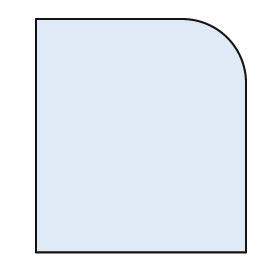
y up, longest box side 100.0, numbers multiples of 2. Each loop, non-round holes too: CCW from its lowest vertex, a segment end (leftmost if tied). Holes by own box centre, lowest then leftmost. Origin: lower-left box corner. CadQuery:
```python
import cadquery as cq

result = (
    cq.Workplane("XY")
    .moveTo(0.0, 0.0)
    .lineTo(90.0, 0.0)
    .lineTo(90.0, 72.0)
    .threePointArc((82.0, 92.0), (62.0, 100.0))
    .lineTo(0.0, 100.0)
    .close()
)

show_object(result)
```